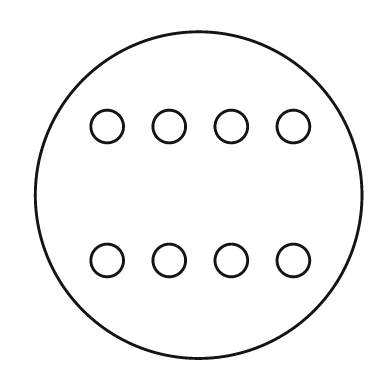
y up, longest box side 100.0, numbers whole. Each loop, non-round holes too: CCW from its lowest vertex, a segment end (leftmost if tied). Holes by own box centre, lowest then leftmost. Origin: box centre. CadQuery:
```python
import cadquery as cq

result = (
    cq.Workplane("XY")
    .moveTo(0.0, 0.0)
    .circle(50.0)
    .moveTo(-28.0, -20.0)
    .circle(5.0)
    .moveTo(-9.0, -20.0)
    .circle(5.0)
    .moveTo(10.0, -20.0)
    .circle(5.0)
    .moveTo(29.0, -20.0)
    .circle(5.0)
    .moveTo(-28.0, 21.0)
    .circle(5.0)
    .moveTo(-9.0, 21.0)
    .circle(5.0)
    .moveTo(10.0, 21.0)
    .circle(5.0)
    .moveTo(29.0, 21.0)
    .circle(5.0)
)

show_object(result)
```